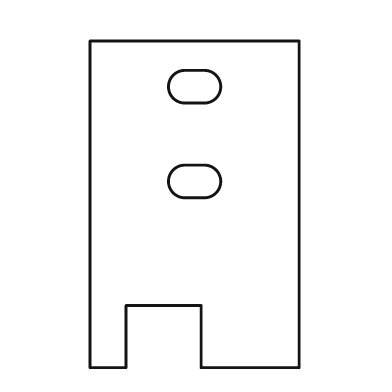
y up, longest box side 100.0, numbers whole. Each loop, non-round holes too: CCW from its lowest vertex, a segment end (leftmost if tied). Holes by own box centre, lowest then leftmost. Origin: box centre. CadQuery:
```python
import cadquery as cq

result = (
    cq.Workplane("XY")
    .moveTo(-32.0, -50.0)
    .lineTo(-21.0, -50.0)
    .lineTo(-21.0, -31.0)
    .lineTo(2.0, -31.0)
    .lineTo(2.0, -50.0)
    .lineTo(32.0, -50.0)
    .lineTo(32.0, 50.0)
    .lineTo(-32.0, 50.0)
    .close()
    .moveTo(-3.0, 2.0)
    .lineTo(3.0, 2.0)
    .threePointArc((8.0, 7.0), (3.0, 12.0))
    .lineTo(-3.0, 12.0)
    .threePointArc((-8.0, 7.0), (-3.0, 2.0))
    .close()
    .moveTo(-3.0, 31.0)
    .lineTo(3.0, 31.0)
    .threePointArc((8.0, 36.0), (3.0, 41.0))
    .lineTo(-3.0, 41.0)
    .threePointArc((-8.0, 36.0), (-3.0, 31.0))
    .close()
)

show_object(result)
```